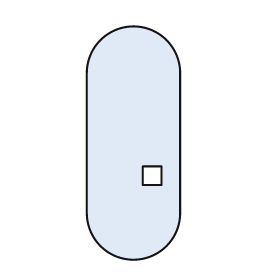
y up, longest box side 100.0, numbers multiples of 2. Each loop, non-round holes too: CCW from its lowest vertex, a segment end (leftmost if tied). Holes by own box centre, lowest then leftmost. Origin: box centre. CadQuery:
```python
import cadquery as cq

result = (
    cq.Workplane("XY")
    .moveTo(-20.0, -30.0)
    .threePointArc((0.0, -50.0), (20.0, -30.0))
    .lineTo(20.0, 30.0)
    .threePointArc((0.0, 50.0), (-20.0, 30.0))
    .close()
    .moveTo(4.0, -18.0)
    .lineTo(12.0, -18.0)
    .lineTo(12.0, -10.0)
    .lineTo(4.0, -10.0)
    .close()
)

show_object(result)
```